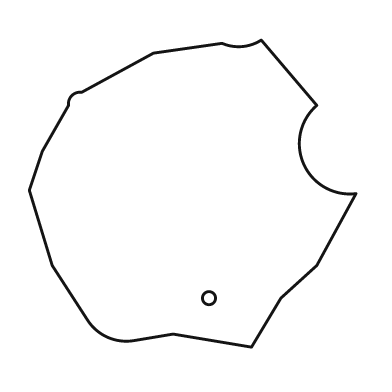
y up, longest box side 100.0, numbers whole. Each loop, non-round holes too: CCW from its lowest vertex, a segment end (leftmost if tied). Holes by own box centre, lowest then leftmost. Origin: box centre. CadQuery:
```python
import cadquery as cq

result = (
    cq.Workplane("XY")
    .moveTo(18.0, -47.0)
    .lineTo(27.0, -32.0)
    .lineTo(38.0, -22.0)
    .lineTo(50.0, 0.0)
    .threePointArc((34.0, 9.0), (38.0, 27.0))
    .lineTo(21.0, 47.0)
    .threePointArc((15.0, 45.0), (9.0, 46.0))
    .lineTo(-12.0, 43.0)
    .lineTo(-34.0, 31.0)
    .threePointArc((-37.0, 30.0), (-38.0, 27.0))
    .lineTo(-46.0, 13.0)
    .lineTo(-50.0, 1.0)
    .lineTo(-43.0, -22.0)
    .lineTo(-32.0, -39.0)
    .threePointArc((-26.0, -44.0), (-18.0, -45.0))
    .lineTo(-6.0, -43.0)
    .close()
    .moveTo(5.0, -32.0)
    .circle(2.0)
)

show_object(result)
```